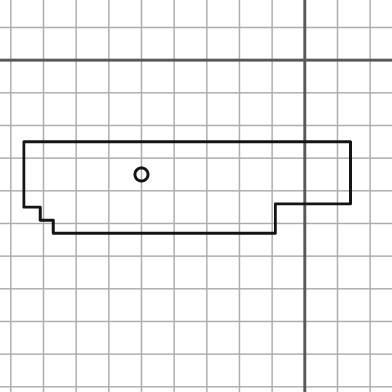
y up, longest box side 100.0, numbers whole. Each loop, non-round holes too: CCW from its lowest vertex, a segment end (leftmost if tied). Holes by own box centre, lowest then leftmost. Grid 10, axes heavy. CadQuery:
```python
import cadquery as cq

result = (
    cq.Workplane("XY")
    .moveTo(-77.0, -53.0)
    .lineTo(-9.0, -53.0)
    .lineTo(-9.0, -44.0)
    .lineTo(14.0, -44.0)
    .lineTo(14.0, -25.0)
    .lineTo(-86.0, -25.0)
    .lineTo(-86.0, -45.0)
    .lineTo(-81.0, -45.0)
    .lineTo(-81.0, -49.0)
    .lineTo(-77.0, -49.0)
    .close()
    .moveTo(-50.0, -35.0)
    .circle(2.0)
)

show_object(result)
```